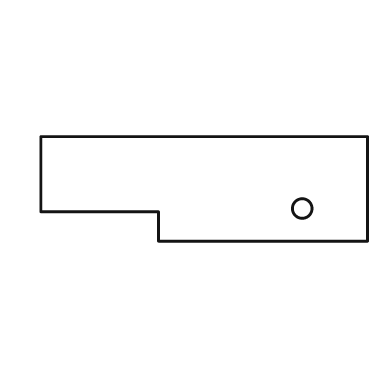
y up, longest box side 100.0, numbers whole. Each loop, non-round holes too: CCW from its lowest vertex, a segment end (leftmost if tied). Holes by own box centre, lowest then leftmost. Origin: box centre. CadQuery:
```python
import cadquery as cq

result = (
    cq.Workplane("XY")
    .moveTo(-14.0, -16.0)
    .lineTo(50.0, -16.0)
    .lineTo(50.0, 16.0)
    .lineTo(-50.0, 16.0)
    .lineTo(-50.0, -7.0)
    .lineTo(-14.0, -7.0)
    .close()
    .moveTo(30.0, -6.0)
    .circle(3.0)
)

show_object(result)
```